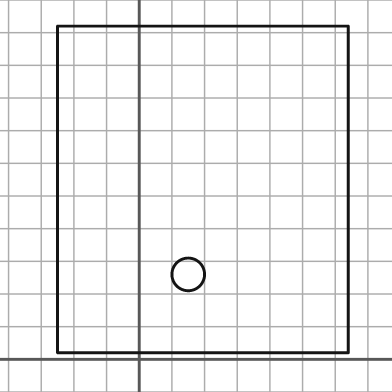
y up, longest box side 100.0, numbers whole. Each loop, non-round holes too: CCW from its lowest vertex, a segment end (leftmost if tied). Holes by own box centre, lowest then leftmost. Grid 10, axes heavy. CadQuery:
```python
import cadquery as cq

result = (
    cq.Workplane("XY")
    .moveTo(-25.0, 2.0)
    .lineTo(64.0, 2.0)
    .lineTo(64.0, 102.0)
    .lineTo(-25.0, 102.0)
    .close()
    .moveTo(15.0, 26.0)
    .circle(5.0)
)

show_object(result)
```